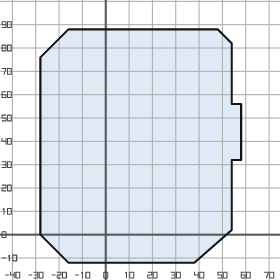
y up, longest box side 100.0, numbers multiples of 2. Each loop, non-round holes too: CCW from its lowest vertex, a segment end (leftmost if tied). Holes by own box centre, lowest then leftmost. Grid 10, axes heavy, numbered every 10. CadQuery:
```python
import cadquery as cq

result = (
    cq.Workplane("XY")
    .moveTo(-16.0, -12.0)
    .lineTo(38.0, -12.0)
    .lineTo(54.0, 2.0)
    .lineTo(54.0, 32.0)
    .lineTo(58.0, 32.0)
    .lineTo(58.0, 56.0)
    .lineTo(54.0, 56.0)
    .lineTo(54.0, 82.0)
    .lineTo(48.0, 88.0)
    .lineTo(-16.0, 88.0)
    .lineTo(-28.0, 76.0)
    .lineTo(-28.0, 0.0)
    .close()
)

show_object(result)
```